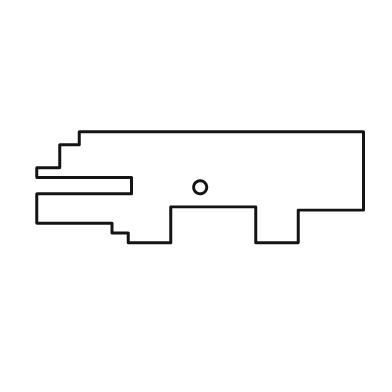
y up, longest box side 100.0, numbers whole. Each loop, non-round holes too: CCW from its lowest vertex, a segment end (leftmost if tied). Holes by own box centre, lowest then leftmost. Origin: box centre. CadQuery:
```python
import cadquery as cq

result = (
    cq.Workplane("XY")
    .moveTo(-22.0, -17.0)
    .lineTo(-9.0, -17.0)
    .lineTo(-9.0, -6.0)
    .lineTo(17.0, -6.0)
    .lineTo(17.0, -17.0)
    .lineTo(30.0, -17.0)
    .lineTo(30.0, -7.0)
    .lineTo(50.0, -7.0)
    .lineTo(50.0, 17.0)
    .lineTo(-37.0, 17.0)
    .lineTo(-37.0, 13.0)
    .lineTo(-43.0, 13.0)
    .lineTo(-43.0, 6.0)
    .lineTo(-50.0, 6.0)
    .lineTo(-50.0, 3.0)
    .lineTo(-21.0, 3.0)
    .lineTo(-21.0, -2.0)
    .lineTo(-50.0, -2.0)
    .lineTo(-50.0, -11.0)
    .lineTo(-27.0, -11.0)
    .lineTo(-27.0, -14.0)
    .lineTo(-22.0, -14.0)
    .close()
    .moveTo(0.0, 0.0)
    .circle(2.0)
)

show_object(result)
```